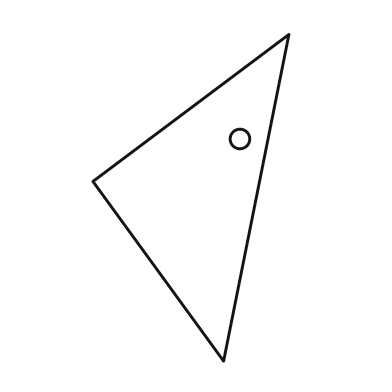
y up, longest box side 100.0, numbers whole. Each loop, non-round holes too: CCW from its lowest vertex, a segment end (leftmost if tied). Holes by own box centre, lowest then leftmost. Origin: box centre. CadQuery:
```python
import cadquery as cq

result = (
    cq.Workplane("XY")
    .moveTo(10.0, -50.0)
    .lineTo(30.0, 50.0)
    .lineTo(-30.0, 5.0)
    .close()
    .moveTo(15.0, 18.0)
    .circle(3.0)
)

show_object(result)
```